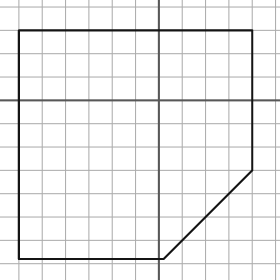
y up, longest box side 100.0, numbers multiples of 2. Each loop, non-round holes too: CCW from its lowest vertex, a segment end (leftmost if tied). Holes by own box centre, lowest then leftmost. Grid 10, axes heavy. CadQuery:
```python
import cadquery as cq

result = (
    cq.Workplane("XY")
    .moveTo(-60.0, -68.0)
    .lineTo(2.0, -68.0)
    .lineTo(40.0, -30.0)
    .lineTo(40.0, 30.0)
    .lineTo(-60.0, 30.0)
    .close()
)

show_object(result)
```